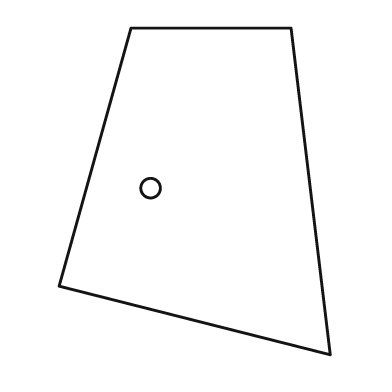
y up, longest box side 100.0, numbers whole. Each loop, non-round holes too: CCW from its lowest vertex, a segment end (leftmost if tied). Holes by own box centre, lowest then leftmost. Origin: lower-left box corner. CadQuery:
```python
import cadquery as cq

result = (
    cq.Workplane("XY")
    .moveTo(83.0, 0.0)
    .lineTo(71.0, 100.0)
    .lineTo(22.0, 100.0)
    .lineTo(0.0, 21.0)
    .close()
    .moveTo(28.0, 51.0)
    .circle(3.0)
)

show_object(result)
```